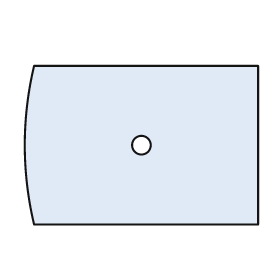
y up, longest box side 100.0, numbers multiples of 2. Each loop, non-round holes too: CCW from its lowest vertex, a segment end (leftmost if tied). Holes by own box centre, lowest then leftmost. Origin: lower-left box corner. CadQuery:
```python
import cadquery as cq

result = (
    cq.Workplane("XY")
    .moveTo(4.0, 0.0)
    .lineTo(100.0, 0.0)
    .lineTo(100.0, 68.0)
    .lineTo(4.0, 68.0)
    .threePointArc((0.0, 34.0), (4.0, 0.0))
    .close()
    .moveTo(50.0, 34.0)
    .circle(4.0)
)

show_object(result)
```